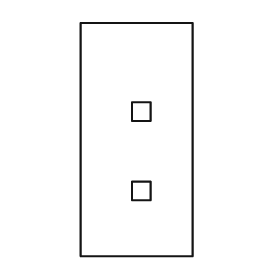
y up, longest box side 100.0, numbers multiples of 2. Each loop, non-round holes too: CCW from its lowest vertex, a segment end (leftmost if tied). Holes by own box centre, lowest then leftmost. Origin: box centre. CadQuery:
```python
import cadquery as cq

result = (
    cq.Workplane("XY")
    .moveTo(-24.0, -50.0)
    .lineTo(24.0, -50.0)
    .lineTo(24.0, 50.0)
    .lineTo(-24.0, 50.0)
    .close()
    .moveTo(-2.0, -26.0)
    .lineTo(6.0, -26.0)
    .lineTo(6.0, -18.0)
    .lineTo(-2.0, -18.0)
    .close()
    .moveTo(-2.0, 8.0)
    .lineTo(6.0, 8.0)
    .lineTo(6.0, 16.0)
    .lineTo(-2.0, 16.0)
    .close()
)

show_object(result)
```